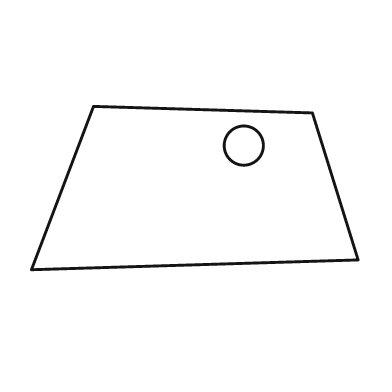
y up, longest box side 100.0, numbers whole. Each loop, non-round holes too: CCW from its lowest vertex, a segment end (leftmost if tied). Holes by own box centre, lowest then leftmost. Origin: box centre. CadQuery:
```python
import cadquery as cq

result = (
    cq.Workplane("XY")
    .moveTo(-50.0, -25.0)
    .lineTo(50.0, -22.0)
    .lineTo(36.0, 23.0)
    .lineTo(-31.0, 25.0)
    .close()
    .moveTo(15.0, 13.0)
    .circle(6.0)
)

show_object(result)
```